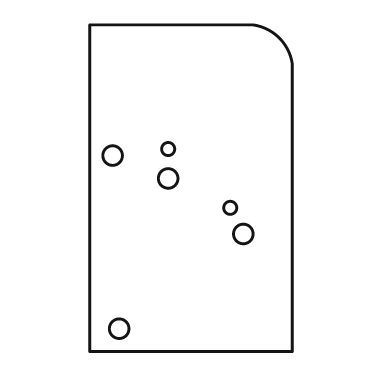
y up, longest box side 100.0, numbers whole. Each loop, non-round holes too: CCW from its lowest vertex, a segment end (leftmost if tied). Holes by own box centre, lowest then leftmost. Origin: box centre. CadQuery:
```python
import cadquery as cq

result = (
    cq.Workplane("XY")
    .moveTo(-31.0, -50.0)
    .lineTo(31.0, -50.0)
    .lineTo(31.0, 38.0)
    .threePointArc((27.0, 46.0), (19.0, 50.0))
    .lineTo(-31.0, 50.0)
    .close()
    .moveTo(-22.0, -43.0)
    .circle(3.0)
    .moveTo(16.0, -14.0)
    .circle(3.0)
    .moveTo(12.0, -6.0)
    .circle(2.0)
    .moveTo(-7.0, 3.0)
    .circle(3.0)
    .moveTo(-24.0, 10.0)
    .circle(3.0)
    .moveTo(-7.0, 12.0)
    .circle(2.0)
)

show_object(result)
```